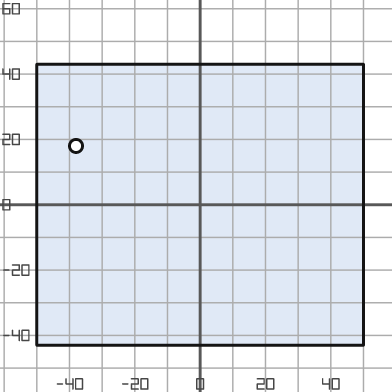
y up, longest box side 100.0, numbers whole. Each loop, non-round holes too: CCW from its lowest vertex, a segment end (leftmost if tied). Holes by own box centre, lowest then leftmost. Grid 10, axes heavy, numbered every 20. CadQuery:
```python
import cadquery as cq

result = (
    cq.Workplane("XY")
    .moveTo(-50.0, -43.0)
    .lineTo(50.0, -43.0)
    .lineTo(50.0, 43.0)
    .lineTo(-50.0, 43.0)
    .close()
    .moveTo(-38.0, 18.0)
    .circle(2.0)
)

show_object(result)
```